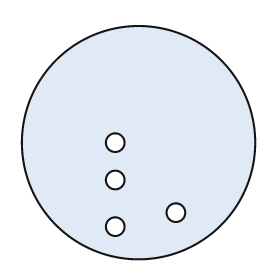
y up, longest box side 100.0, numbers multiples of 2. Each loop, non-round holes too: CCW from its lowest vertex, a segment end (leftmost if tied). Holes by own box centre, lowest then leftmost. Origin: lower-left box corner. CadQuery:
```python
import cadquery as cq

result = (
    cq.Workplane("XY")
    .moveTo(50.0, 50.0)
    .circle(50.0)
    .moveTo(40.0, 14.0)
    .circle(4.0)
    .moveTo(66.0, 20.0)
    .circle(4.0)
    .moveTo(40.0, 34.0)
    .circle(4.0)
    .moveTo(40.0, 50.0)
    .circle(4.0)
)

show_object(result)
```